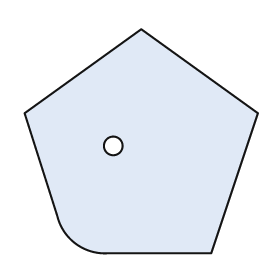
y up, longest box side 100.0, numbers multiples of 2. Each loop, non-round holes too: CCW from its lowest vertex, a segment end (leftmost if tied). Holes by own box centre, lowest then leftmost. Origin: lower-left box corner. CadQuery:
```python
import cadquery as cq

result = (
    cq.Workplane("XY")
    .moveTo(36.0, 0.0)
    .lineTo(80.0, 0.0)
    .lineTo(100.0, 60.0)
    .lineTo(50.0, 96.0)
    .lineTo(0.0, 60.0)
    .lineTo(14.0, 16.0)
    .threePointArc((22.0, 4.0), (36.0, 0.0))
    .close()
    .moveTo(38.0, 46.0)
    .circle(4.0)
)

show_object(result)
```